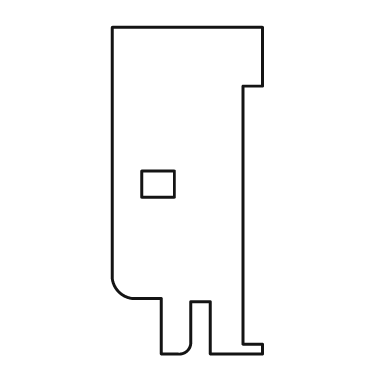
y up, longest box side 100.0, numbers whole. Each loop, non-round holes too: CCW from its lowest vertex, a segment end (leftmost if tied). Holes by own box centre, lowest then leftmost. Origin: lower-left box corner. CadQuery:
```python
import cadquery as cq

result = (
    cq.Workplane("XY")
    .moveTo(15.0, 0.0)
    .lineTo(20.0, 0.0)
    .threePointArc((23.0, 1.0), (24.0, 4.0))
    .lineTo(24.0, 16.0)
    .lineTo(30.0, 16.0)
    .lineTo(30.0, 0.0)
    .lineTo(46.0, 0.0)
    .lineTo(46.0, 3.0)
    .lineTo(40.0, 3.0)
    .lineTo(40.0, 82.0)
    .lineTo(46.0, 82.0)
    .lineTo(46.0, 100.0)
    .lineTo(0.0, 100.0)
    .lineTo(0.0, 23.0)
    .threePointArc((2.0, 19.0), (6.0, 17.0))
    .lineTo(15.0, 17.0)
    .close()
    .moveTo(9.0, 48.0)
    .lineTo(19.0, 48.0)
    .lineTo(19.0, 56.0)
    .lineTo(9.0, 56.0)
    .close()
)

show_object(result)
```